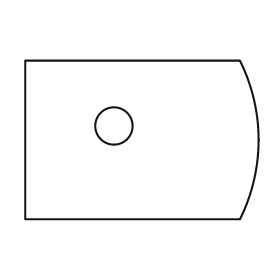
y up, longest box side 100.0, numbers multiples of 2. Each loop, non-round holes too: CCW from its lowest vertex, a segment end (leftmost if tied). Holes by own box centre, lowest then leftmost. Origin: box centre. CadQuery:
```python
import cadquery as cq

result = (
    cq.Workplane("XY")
    .moveTo(-50.0, -34.0)
    .lineTo(42.0, -34.0)
    .threePointArc((50.0, 0.0), (42.0, 34.0))
    .lineTo(-50.0, 34.0)
    .close()
    .moveTo(-12.0, 6.0)
    .circle(8.0)
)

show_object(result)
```